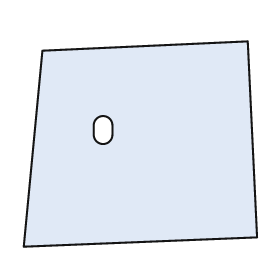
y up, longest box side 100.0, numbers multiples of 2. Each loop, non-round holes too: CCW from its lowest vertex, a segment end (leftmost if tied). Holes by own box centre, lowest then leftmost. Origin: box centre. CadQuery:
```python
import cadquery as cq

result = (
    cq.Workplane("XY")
    .moveTo(-50.0, -44.0)
    .lineTo(50.0, -40.0)
    .lineTo(46.0, 44.0)
    .lineTo(-42.0, 40.0)
    .close()
    .moveTo(-20.0, 4.0)
    .threePointArc((-16.0, 0.0), (-12.0, 4.0))
    .lineTo(-12.0, 8.0)
    .threePointArc((-16.0, 12.0), (-20.0, 8.0))
    .close()
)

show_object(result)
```